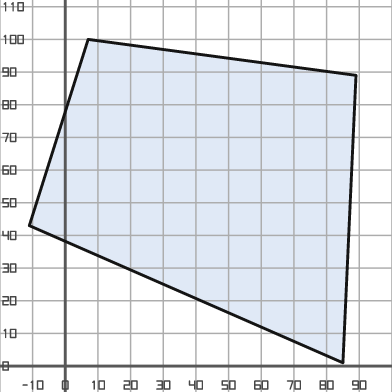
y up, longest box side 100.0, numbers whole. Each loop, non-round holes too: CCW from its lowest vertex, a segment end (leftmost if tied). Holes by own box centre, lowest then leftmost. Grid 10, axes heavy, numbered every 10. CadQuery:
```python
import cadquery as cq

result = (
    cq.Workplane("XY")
    .moveTo(85.0, 1.0)
    .lineTo(89.0, 89.0)
    .lineTo(7.0, 100.0)
    .lineTo(-11.0, 43.0)
    .close()
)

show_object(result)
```